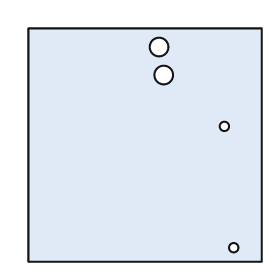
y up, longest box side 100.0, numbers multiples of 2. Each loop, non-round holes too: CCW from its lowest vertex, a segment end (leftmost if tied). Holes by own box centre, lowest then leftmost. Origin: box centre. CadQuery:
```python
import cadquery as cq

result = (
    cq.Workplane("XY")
    .moveTo(-50.0, -50.0)
    .lineTo(50.0, -50.0)
    .lineTo(50.0, 50.0)
    .lineTo(-50.0, 50.0)
    .close()
    .moveTo(38.0, -44.0)
    .circle(2.0)
    .moveTo(34.0, 8.0)
    .circle(2.0)
    .moveTo(8.0, 30.0)
    .circle(4.0)
    .moveTo(6.0, 42.0)
    .circle(4.0)
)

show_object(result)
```